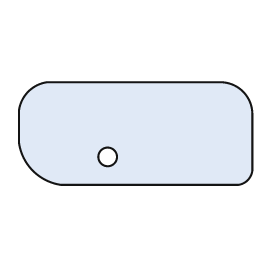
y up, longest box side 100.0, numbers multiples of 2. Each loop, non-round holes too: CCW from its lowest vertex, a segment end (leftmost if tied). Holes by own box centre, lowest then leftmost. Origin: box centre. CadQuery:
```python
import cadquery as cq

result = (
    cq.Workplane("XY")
    .moveTo(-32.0, -22.0)
    .lineTo(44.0, -22.0)
    .threePointArc((48.0, -20.0), (50.0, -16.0))
    .lineTo(50.0, 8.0)
    .threePointArc((46.0, 18.0), (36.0, 22.0))
    .lineTo(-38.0, 22.0)
    .threePointArc((-46.0, 18.0), (-50.0, 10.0))
    .lineTo(-50.0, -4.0)
    .threePointArc((-44.0, -16.0), (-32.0, -22.0))
    .close()
    .moveTo(-12.0, -10.0)
    .circle(4.0)
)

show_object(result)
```